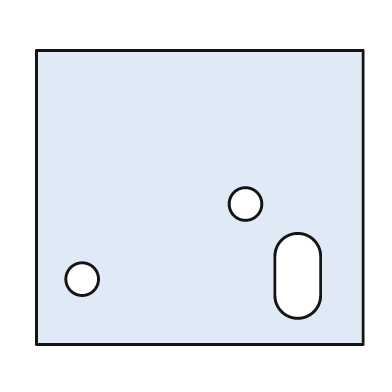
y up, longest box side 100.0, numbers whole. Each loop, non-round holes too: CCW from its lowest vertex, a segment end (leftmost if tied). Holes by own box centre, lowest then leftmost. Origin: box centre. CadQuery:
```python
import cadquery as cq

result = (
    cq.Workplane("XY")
    .moveTo(-50.0, -45.0)
    .lineTo(50.0, -45.0)
    .lineTo(50.0, 45.0)
    .lineTo(-50.0, 45.0)
    .close()
    .moveTo(-36.0, -25.0)
    .circle(5.0)
    .moveTo(23.0, -30.0)
    .threePointArc((30.0, -37.0), (37.0, -30.0))
    .lineTo(37.0, -18.0)
    .threePointArc((30.0, -11.0), (23.0, -18.0))
    .close()
    .moveTo(14.0, -2.0)
    .circle(5.0)
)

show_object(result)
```